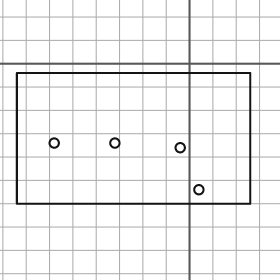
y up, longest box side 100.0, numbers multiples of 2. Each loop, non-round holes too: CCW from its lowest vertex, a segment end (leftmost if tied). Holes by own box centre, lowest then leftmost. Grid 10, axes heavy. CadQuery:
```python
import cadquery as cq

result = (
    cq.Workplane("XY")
    .moveTo(-74.0, -60.0)
    .lineTo(26.0, -60.0)
    .lineTo(26.0, -4.0)
    .lineTo(-74.0, -4.0)
    .close()
    .moveTo(4.0, -54.0)
    .circle(2.0)
    .moveTo(-4.0, -36.0)
    .circle(2.0)
    .moveTo(-58.0, -34.0)
    .circle(2.0)
    .moveTo(-32.0, -34.0)
    .circle(2.0)
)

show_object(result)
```